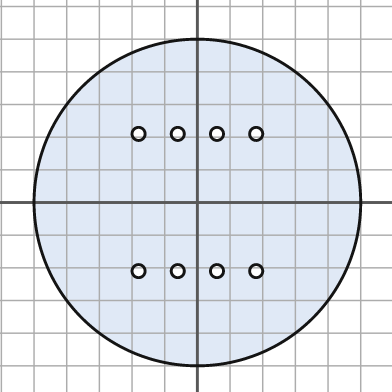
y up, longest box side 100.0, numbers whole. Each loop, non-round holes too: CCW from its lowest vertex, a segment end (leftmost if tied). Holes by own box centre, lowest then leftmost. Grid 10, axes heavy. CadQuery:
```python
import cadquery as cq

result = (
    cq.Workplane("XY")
    .moveTo(0.0, 0.0)
    .circle(50.0)
    .moveTo(-18.0, -21.0)
    .circle(2.0)
    .moveTo(-6.0, -21.0)
    .circle(2.0)
    .moveTo(6.0, -21.0)
    .circle(2.0)
    .moveTo(18.0, -21.0)
    .circle(2.0)
    .moveTo(-18.0, 21.0)
    .circle(2.0)
    .moveTo(-6.0, 21.0)
    .circle(2.0)
    .moveTo(6.0, 21.0)
    .circle(2.0)
    .moveTo(18.0, 21.0)
    .circle(2.0)
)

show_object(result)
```